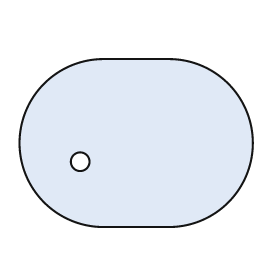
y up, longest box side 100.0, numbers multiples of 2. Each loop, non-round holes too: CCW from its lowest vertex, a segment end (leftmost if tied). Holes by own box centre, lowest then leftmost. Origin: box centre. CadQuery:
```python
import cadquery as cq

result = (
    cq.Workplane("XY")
    .moveTo(-14.0, -36.0)
    .lineTo(14.0, -36.0)
    .threePointArc((50.0, 0.0), (14.0, 36.0))
    .lineTo(-14.0, 36.0)
    .threePointArc((-50.0, 0.0), (-14.0, -36.0))
    .close()
    .moveTo(-24.0, -8.0)
    .circle(4.0)
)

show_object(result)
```